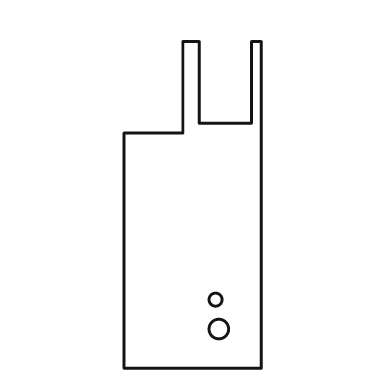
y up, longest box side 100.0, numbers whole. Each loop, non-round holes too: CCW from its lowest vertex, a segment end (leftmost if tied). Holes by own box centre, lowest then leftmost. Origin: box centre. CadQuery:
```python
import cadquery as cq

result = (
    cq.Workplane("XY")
    .moveTo(-21.0, -50.0)
    .lineTo(21.0, -50.0)
    .lineTo(21.0, 50.0)
    .lineTo(18.0, 50.0)
    .lineTo(18.0, 25.0)
    .lineTo(2.0, 25.0)
    .lineTo(2.0, 50.0)
    .lineTo(-3.0, 50.0)
    .lineTo(-3.0, 22.0)
    .lineTo(-21.0, 22.0)
    .close()
    .moveTo(8.0, -38.0)
    .circle(3.0)
    .moveTo(7.0, -29.0)
    .circle(2.0)
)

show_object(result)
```